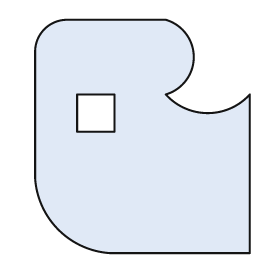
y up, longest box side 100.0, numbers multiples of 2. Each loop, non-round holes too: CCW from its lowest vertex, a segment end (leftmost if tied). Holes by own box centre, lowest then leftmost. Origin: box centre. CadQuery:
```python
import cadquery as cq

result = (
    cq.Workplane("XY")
    .moveTo(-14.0, -50.0)
    .lineTo(46.0, -50.0)
    .lineTo(46.0, 18.0)
    .threePointArc((28.0, 10.0), (10.0, 18.0))
    .threePointArc((22.0, 34.0), (10.0, 50.0))
    .lineTo(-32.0, 50.0)
    .threePointArc((-42.0, 46.0), (-46.0, 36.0))
    .lineTo(-46.0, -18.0)
    .threePointArc((-36.0, -40.0), (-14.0, -50.0))
    .close()
    .moveTo(-28.0, 2.0)
    .lineTo(-12.0, 2.0)
    .lineTo(-12.0, 18.0)
    .lineTo(-28.0, 18.0)
    .close()
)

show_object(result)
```